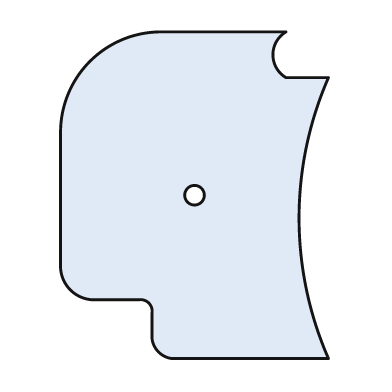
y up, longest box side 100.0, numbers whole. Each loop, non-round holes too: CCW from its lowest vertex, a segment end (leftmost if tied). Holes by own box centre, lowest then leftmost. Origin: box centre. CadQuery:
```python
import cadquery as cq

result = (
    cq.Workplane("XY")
    .moveTo(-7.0, -50.0)
    .lineTo(41.0, -50.0)
    .threePointArc((32.0, -7.0), (41.0, 36.0))
    .lineTo(28.0, 36.0)
    .threePointArc((24.0, 43.0), (28.0, 50.0))
    .lineTo(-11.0, 50.0)
    .threePointArc((-32.0, 41.0), (-41.0, 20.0))
    .lineTo(-41.0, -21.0)
    .threePointArc((-38.0, -29.0), (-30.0, -32.0))
    .lineTo(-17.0, -32.0)
    .threePointArc((-14.0, -33.0), (-13.0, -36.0))
    .lineTo(-13.0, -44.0)
    .threePointArc((-11.0, -48.0), (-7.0, -50.0))
    .close()
    .moveTo(0.0, 0.0)
    .circle(3.0)
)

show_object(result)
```